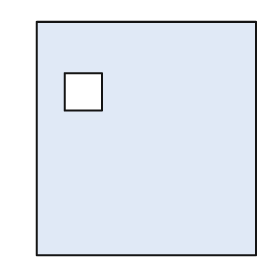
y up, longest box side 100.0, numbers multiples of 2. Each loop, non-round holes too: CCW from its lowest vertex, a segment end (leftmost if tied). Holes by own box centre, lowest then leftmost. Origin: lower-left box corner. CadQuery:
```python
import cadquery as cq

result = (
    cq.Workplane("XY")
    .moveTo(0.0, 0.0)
    .lineTo(94.0, 0.0)
    .lineTo(94.0, 100.0)
    .lineTo(0.0, 100.0)
    .close()
    .moveTo(12.0, 62.0)
    .lineTo(28.0, 62.0)
    .lineTo(28.0, 78.0)
    .lineTo(12.0, 78.0)
    .close()
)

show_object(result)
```